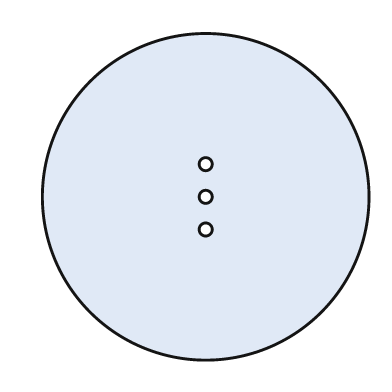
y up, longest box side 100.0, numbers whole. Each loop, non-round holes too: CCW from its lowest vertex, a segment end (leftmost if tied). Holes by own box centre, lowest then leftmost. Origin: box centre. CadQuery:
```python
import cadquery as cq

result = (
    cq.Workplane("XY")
    .moveTo(0.0, 0.0)
    .circle(50.0)
    .moveTo(0.0, -10.0)
    .circle(2.0)
    .moveTo(0.0, 0.0)
    .circle(2.0)
    .moveTo(0.0, 10.0)
    .circle(2.0)
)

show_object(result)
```